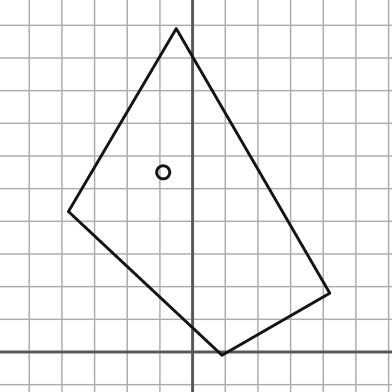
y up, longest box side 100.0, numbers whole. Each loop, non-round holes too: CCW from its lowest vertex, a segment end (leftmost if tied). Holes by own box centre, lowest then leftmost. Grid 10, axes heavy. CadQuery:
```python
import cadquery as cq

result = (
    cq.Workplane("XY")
    .moveTo(9.0, -1.0)
    .lineTo(42.0, 18.0)
    .lineTo(-5.0, 99.0)
    .lineTo(-38.0, 43.0)
    .close()
    .moveTo(-9.0, 55.0)
    .circle(2.0)
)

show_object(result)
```